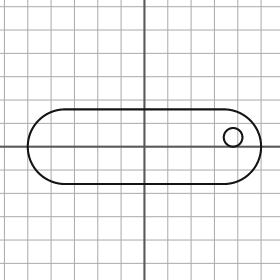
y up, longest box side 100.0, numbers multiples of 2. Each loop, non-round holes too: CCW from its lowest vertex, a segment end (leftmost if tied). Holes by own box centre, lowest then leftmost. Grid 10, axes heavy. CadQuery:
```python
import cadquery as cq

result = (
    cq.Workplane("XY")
    .moveTo(-34.0, -16.0)
    .lineTo(34.0, -16.0)
    .threePointArc((50.0, 0.0), (34.0, 16.0))
    .lineTo(-34.0, 16.0)
    .threePointArc((-50.0, 0.0), (-34.0, -16.0))
    .close()
    .moveTo(38.0, 4.0)
    .circle(4.0)
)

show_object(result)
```